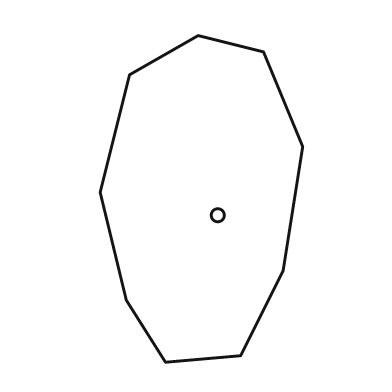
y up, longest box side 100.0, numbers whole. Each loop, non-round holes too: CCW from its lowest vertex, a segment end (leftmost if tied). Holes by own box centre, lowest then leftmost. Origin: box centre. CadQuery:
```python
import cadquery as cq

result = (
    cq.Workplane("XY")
    .moveTo(-11.0, -50.0)
    .lineTo(12.0, -48.0)
    .lineTo(25.0, -22.0)
    .lineTo(31.0, 16.0)
    .lineTo(19.0, 45.0)
    .lineTo(-1.0, 50.0)
    .lineTo(-22.0, 38.0)
    .lineTo(-31.0, 2.0)
    .lineTo(-23.0, -31.0)
    .close()
    .moveTo(5.0, -5.0)
    .circle(2.0)
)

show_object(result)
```